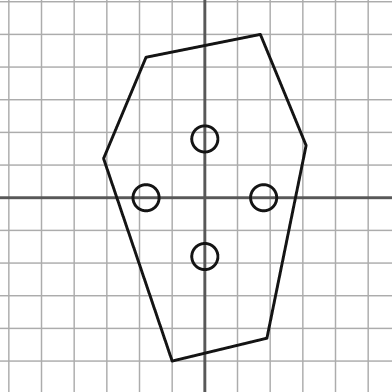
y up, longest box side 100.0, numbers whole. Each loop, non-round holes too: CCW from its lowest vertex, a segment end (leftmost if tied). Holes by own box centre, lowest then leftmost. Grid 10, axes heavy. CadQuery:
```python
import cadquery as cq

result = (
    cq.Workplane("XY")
    .moveTo(-10.0, -50.0)
    .lineTo(19.0, -43.0)
    .lineTo(31.0, 16.0)
    .lineTo(17.0, 50.0)
    .lineTo(-18.0, 43.0)
    .lineTo(-31.0, 12.0)
    .close()
    .moveTo(0.0, -18.0)
    .circle(4.0)
    .moveTo(-18.0, 0.0)
    .circle(4.0)
    .moveTo(18.0, 0.0)
    .circle(4.0)
    .moveTo(0.0, 18.0)
    .circle(4.0)
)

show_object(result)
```